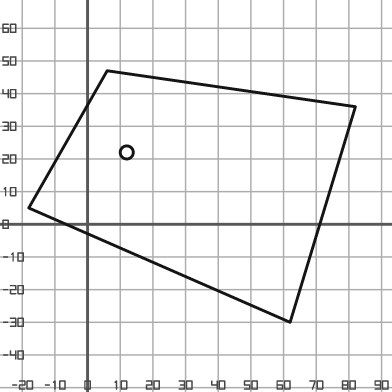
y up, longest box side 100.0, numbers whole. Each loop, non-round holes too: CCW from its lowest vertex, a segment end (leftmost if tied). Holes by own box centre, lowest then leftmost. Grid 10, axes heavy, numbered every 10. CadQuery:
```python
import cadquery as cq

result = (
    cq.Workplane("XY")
    .moveTo(62.0, -30.0)
    .lineTo(82.0, 36.0)
    .lineTo(6.0, 47.0)
    .lineTo(-18.0, 5.0)
    .close()
    .moveTo(12.0, 22.0)
    .circle(2.0)
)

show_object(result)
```